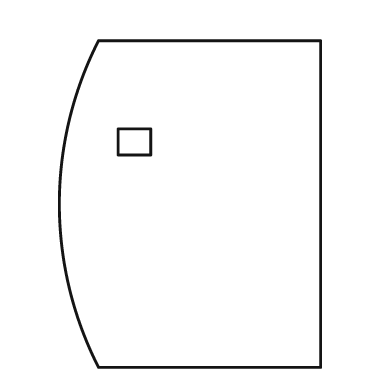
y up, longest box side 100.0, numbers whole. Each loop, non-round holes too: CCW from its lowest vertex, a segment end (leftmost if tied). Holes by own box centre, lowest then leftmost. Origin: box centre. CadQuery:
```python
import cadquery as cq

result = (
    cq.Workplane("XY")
    .moveTo(-28.0, -50.0)
    .lineTo(40.0, -50.0)
    .lineTo(40.0, 50.0)
    .lineTo(-28.0, 50.0)
    .threePointArc((-40.0, 0.0), (-28.0, -50.0))
    .close()
    .moveTo(-22.0, 15.0)
    .lineTo(-12.0, 15.0)
    .lineTo(-12.0, 23.0)
    .lineTo(-22.0, 23.0)
    .close()
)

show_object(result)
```